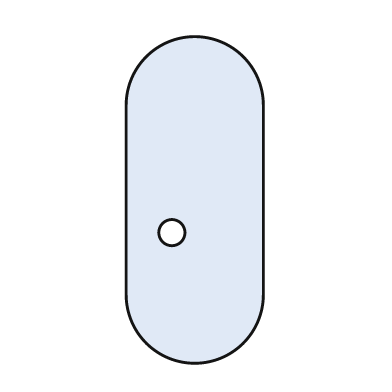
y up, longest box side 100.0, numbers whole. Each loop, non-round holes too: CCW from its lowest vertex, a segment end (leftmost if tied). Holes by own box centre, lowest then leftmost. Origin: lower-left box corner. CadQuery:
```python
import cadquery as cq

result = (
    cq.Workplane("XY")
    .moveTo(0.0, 21.0)
    .threePointArc((21.0, 0.0), (42.0, 21.0))
    .lineTo(42.0, 79.0)
    .threePointArc((21.0, 100.0), (0.0, 79.0))
    .close()
    .moveTo(14.0, 40.0)
    .circle(4.0)
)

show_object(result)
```